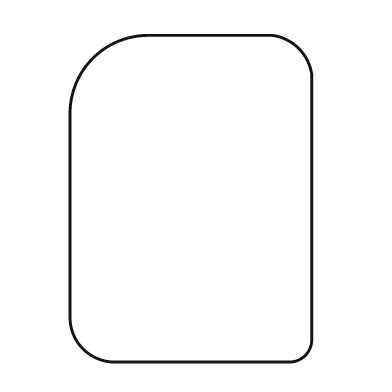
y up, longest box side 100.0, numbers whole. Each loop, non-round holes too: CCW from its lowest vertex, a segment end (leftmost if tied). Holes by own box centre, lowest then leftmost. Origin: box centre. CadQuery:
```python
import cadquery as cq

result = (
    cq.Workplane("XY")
    .moveTo(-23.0, -50.0)
    .lineTo(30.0, -50.0)
    .threePointArc((35.0, -48.0), (37.0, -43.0))
    .lineTo(37.0, 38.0)
    .threePointArc((33.0, 46.0), (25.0, 50.0))
    .lineTo(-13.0, 50.0)
    .threePointArc((-30.0, 43.0), (-37.0, 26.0))
    .lineTo(-37.0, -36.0)
    .threePointArc((-33.0, -46.0), (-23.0, -50.0))
    .close()
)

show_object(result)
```